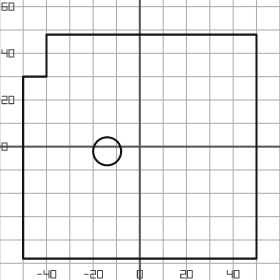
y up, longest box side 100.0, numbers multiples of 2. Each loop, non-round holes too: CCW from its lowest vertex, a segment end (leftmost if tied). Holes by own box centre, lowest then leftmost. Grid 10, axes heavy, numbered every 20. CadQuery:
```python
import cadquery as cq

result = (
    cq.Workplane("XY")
    .moveTo(-50.0, -48.0)
    .lineTo(50.0, -48.0)
    .lineTo(50.0, 48.0)
    .lineTo(-40.0, 48.0)
    .lineTo(-40.0, 30.0)
    .lineTo(-50.0, 30.0)
    .close()
    .moveTo(-14.0, -2.0)
    .circle(6.0)
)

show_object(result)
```